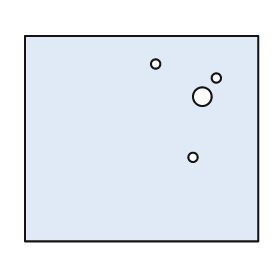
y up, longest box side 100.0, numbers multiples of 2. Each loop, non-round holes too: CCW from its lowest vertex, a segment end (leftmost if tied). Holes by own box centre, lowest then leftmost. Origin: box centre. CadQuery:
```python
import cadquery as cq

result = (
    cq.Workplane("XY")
    .moveTo(-50.0, -44.0)
    .lineTo(50.0, -44.0)
    .lineTo(50.0, 44.0)
    .lineTo(-50.0, 44.0)
    .close()
    .moveTo(22.0, -8.0)
    .circle(2.0)
    .moveTo(26.0, 18.0)
    .circle(4.0)
    .moveTo(32.0, 26.0)
    .circle(2.0)
    .moveTo(6.0, 32.0)
    .circle(2.0)
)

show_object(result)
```